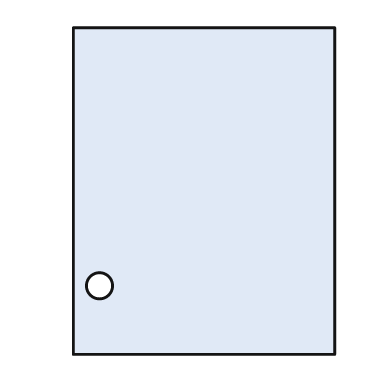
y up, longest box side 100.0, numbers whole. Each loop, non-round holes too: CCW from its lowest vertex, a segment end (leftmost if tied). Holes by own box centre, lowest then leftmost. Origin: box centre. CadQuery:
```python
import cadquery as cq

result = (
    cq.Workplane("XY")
    .moveTo(-40.0, -50.0)
    .lineTo(40.0, -50.0)
    .lineTo(40.0, 50.0)
    .lineTo(-40.0, 50.0)
    .close()
    .moveTo(-32.0, -29.0)
    .circle(4.0)
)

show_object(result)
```